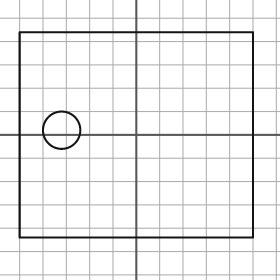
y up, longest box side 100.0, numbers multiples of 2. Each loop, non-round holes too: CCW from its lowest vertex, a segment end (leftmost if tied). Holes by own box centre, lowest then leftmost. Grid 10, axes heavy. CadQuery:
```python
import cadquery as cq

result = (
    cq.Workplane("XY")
    .moveTo(-50.0, -44.0)
    .lineTo(50.0, -44.0)
    .lineTo(50.0, 44.0)
    .lineTo(-50.0, 44.0)
    .close()
    .moveTo(-32.0, 2.0)
    .circle(8.0)
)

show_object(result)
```